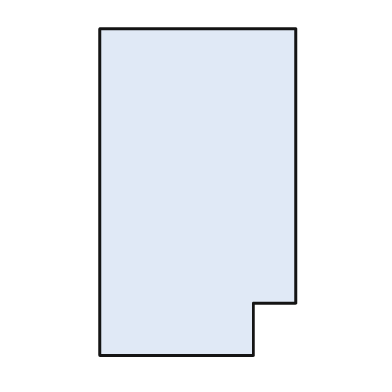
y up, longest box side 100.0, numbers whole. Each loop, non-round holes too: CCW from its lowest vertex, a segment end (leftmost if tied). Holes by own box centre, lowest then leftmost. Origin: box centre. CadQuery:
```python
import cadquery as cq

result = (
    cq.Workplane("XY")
    .moveTo(-30.0, -50.0)
    .lineTo(17.0, -50.0)
    .lineTo(17.0, -34.0)
    .lineTo(30.0, -34.0)
    .lineTo(30.0, 50.0)
    .lineTo(-30.0, 50.0)
    .close()
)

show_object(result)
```